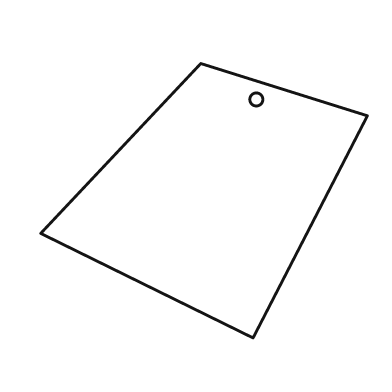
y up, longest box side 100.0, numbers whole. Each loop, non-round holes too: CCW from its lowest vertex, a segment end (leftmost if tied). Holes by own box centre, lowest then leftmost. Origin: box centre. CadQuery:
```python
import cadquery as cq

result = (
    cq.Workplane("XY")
    .moveTo(15.0, -42.0)
    .lineTo(50.0, 26.0)
    .lineTo(-1.0, 42.0)
    .lineTo(-50.0, -10.0)
    .close()
    .moveTo(16.0, 31.0)
    .circle(2.0)
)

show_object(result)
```